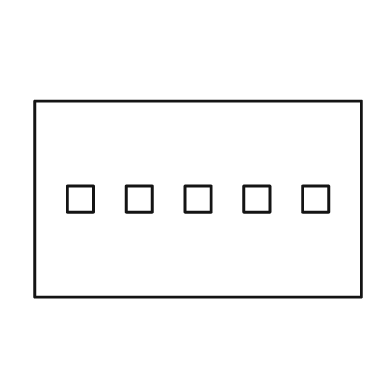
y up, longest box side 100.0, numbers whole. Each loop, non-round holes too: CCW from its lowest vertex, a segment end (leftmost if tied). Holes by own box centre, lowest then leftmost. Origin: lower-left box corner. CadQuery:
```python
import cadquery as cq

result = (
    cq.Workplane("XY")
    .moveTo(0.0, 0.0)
    .lineTo(100.0, 0.0)
    .lineTo(100.0, 60.0)
    .lineTo(0.0, 60.0)
    .close()
    .moveTo(10.0, 26.0)
    .lineTo(18.0, 26.0)
    .lineTo(18.0, 34.0)
    .lineTo(10.0, 34.0)
    .close()
    .moveTo(28.0, 26.0)
    .lineTo(36.0, 26.0)
    .lineTo(36.0, 34.0)
    .lineTo(28.0, 34.0)
    .close()
    .moveTo(46.0, 26.0)
    .lineTo(54.0, 26.0)
    .lineTo(54.0, 34.0)
    .lineTo(46.0, 34.0)
    .close()
    .moveTo(64.0, 26.0)
    .lineTo(72.0, 26.0)
    .lineTo(72.0, 34.0)
    .lineTo(64.0, 34.0)
    .close()
    .moveTo(82.0, 26.0)
    .lineTo(90.0, 26.0)
    .lineTo(90.0, 34.0)
    .lineTo(82.0, 34.0)
    .close()
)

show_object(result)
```